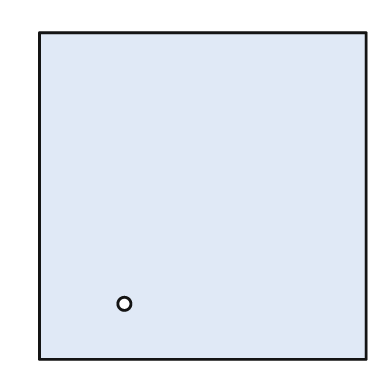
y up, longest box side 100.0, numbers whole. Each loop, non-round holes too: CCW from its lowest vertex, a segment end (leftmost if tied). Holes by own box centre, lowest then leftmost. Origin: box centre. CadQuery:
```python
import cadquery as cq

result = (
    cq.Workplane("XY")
    .moveTo(-50.0, -50.0)
    .lineTo(50.0, -50.0)
    .lineTo(50.0, 50.0)
    .lineTo(-50.0, 50.0)
    .close()
    .moveTo(-24.0, -33.0)
    .circle(2.0)
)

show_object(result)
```